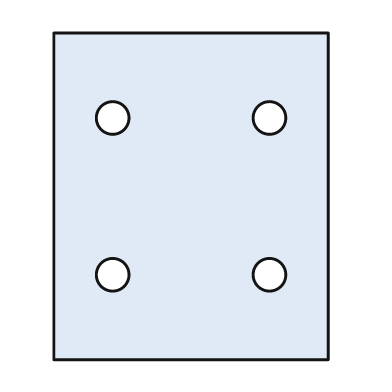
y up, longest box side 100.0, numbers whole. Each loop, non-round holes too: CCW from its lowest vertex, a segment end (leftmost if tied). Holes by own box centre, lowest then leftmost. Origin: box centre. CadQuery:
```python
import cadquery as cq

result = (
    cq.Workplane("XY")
    .moveTo(-42.0, -50.0)
    .lineTo(42.0, -50.0)
    .lineTo(42.0, 50.0)
    .lineTo(-42.0, 50.0)
    .close()
    .moveTo(-24.0, -24.0)
    .circle(5.0)
    .moveTo(24.0, -24.0)
    .circle(5.0)
    .moveTo(-24.0, 24.0)
    .circle(5.0)
    .moveTo(24.0, 24.0)
    .circle(5.0)
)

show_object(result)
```